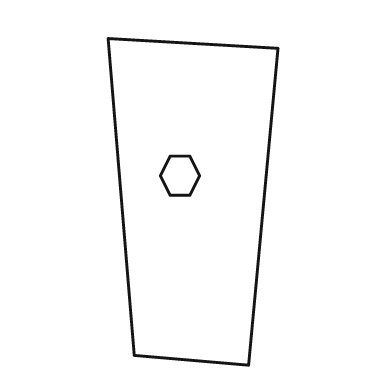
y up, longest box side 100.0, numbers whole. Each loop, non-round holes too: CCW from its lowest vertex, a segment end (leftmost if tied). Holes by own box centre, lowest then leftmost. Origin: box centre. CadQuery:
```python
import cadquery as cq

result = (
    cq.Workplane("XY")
    .moveTo(17.0, -50.0)
    .lineTo(26.0, 47.0)
    .lineTo(-26.0, 50.0)
    .lineTo(-18.0, -47.0)
    .close()
    .moveTo(-7.0, 2.0)
    .lineTo(-1.0, 2.0)
    .lineTo(2.0, 8.0)
    .lineTo(-1.0, 14.0)
    .lineTo(-7.0, 14.0)
    .lineTo(-10.0, 8.0)
    .close()
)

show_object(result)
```